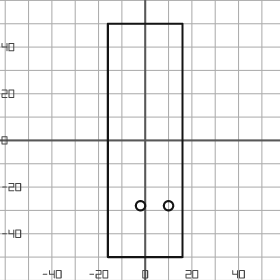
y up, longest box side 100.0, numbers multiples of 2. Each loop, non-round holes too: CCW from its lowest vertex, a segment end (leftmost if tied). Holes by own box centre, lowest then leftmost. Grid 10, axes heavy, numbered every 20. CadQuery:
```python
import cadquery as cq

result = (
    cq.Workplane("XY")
    .moveTo(-16.0, -50.0)
    .lineTo(16.0, -50.0)
    .lineTo(16.0, 50.0)
    .lineTo(-16.0, 50.0)
    .close()
    .moveTo(-2.0, -28.0)
    .circle(2.0)
    .moveTo(10.0, -28.0)
    .circle(2.0)
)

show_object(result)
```